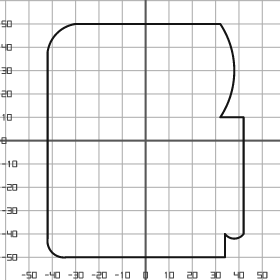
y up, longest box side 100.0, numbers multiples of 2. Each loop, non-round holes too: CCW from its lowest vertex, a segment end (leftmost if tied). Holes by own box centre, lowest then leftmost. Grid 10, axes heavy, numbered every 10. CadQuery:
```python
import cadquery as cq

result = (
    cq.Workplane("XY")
    .moveTo(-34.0, -50.0)
    .lineTo(34.0, -50.0)
    .lineTo(34.0, -40.0)
    .threePointArc((38.0, -42.0), (42.0, -40.0))
    .lineTo(42.0, 10.0)
    .lineTo(32.0, 10.0)
    .threePointArc((38.0, 30.0), (32.0, 50.0))
    .lineTo(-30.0, 50.0)
    .threePointArc((-38.0, 46.0), (-42.0, 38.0))
    .lineTo(-42.0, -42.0)
    .threePointArc((-40.0, -48.0), (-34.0, -50.0))
    .close()
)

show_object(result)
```